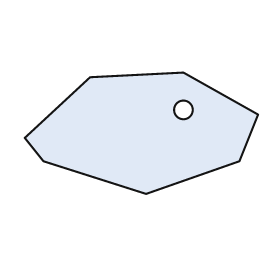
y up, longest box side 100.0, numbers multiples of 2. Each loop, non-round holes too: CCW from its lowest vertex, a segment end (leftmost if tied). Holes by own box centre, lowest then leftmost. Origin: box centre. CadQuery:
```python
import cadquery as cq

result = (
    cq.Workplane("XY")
    .moveTo(2.0, -26.0)
    .lineTo(42.0, -12.0)
    .lineTo(50.0, 8.0)
    .lineTo(18.0, 26.0)
    .lineTo(-22.0, 24.0)
    .lineTo(-50.0, -2.0)
    .lineTo(-42.0, -12.0)
    .close()
    .moveTo(18.0, 10.0)
    .circle(4.0)
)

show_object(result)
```